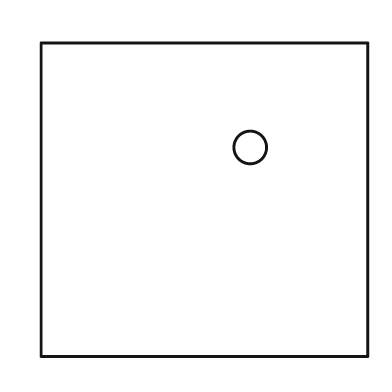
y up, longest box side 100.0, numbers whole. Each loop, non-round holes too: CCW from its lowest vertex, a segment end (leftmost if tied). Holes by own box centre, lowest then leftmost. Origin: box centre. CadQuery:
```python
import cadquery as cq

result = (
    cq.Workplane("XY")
    .moveTo(-50.0, -48.0)
    .lineTo(50.0, -48.0)
    .lineTo(50.0, 48.0)
    .lineTo(-50.0, 48.0)
    .close()
    .moveTo(14.0, 16.0)
    .circle(5.0)
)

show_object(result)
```